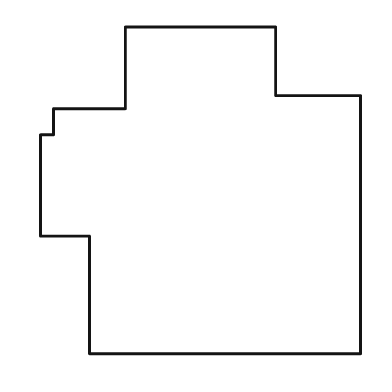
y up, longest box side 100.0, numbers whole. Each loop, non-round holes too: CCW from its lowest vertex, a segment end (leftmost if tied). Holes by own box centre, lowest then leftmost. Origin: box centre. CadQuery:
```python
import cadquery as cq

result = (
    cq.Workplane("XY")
    .moveTo(-34.0, -50.0)
    .lineTo(49.0, -50.0)
    .lineTo(49.0, 29.0)
    .lineTo(23.0, 29.0)
    .lineTo(23.0, 50.0)
    .lineTo(-23.0, 50.0)
    .lineTo(-23.0, 25.0)
    .lineTo(-45.0, 25.0)
    .lineTo(-45.0, 17.0)
    .lineTo(-49.0, 17.0)
    .lineTo(-49.0, -14.0)
    .lineTo(-34.0, -14.0)
    .close()
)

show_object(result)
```